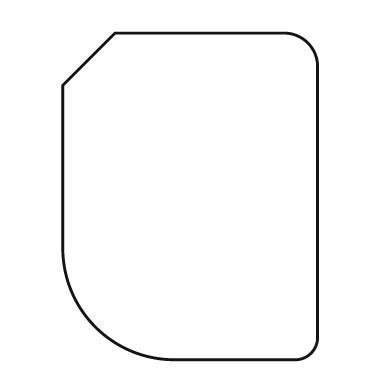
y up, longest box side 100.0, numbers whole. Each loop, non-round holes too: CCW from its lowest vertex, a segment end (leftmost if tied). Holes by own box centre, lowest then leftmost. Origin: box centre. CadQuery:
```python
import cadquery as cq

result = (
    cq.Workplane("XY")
    .moveTo(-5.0, -50.0)
    .lineTo(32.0, -50.0)
    .threePointArc((37.0, -48.0), (39.0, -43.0))
    .lineTo(39.0, 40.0)
    .threePointArc((36.0, 47.0), (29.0, 50.0))
    .lineTo(-23.0, 50.0)
    .lineTo(-39.0, 34.0)
    .lineTo(-39.0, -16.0)
    .threePointArc((-29.0, -40.0), (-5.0, -50.0))
    .close()
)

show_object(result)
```